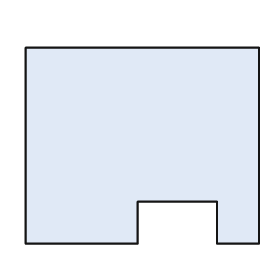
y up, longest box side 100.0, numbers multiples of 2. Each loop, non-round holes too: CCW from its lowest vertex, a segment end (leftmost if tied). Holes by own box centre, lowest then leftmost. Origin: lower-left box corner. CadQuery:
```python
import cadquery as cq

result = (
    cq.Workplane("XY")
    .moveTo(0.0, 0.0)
    .lineTo(48.0, 0.0)
    .lineTo(48.0, 18.0)
    .lineTo(82.0, 18.0)
    .lineTo(82.0, 0.0)
    .lineTo(100.0, 0.0)
    .lineTo(100.0, 84.0)
    .lineTo(0.0, 84.0)
    .close()
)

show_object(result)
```